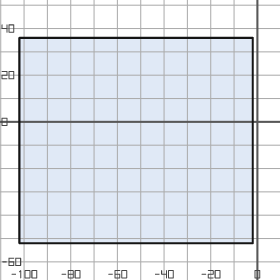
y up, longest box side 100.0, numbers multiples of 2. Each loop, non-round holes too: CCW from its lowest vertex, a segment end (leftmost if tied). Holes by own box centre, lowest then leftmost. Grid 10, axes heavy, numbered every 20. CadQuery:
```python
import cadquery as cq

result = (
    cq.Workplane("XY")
    .moveTo(-102.0, -52.0)
    .lineTo(-2.0, -52.0)
    .lineTo(-2.0, 36.0)
    .lineTo(-102.0, 36.0)
    .close()
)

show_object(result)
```